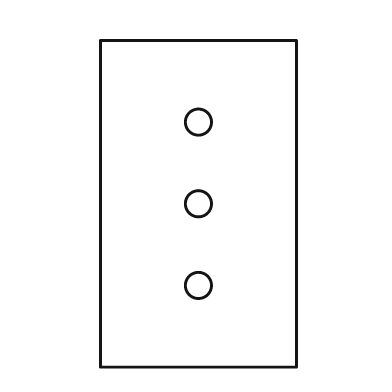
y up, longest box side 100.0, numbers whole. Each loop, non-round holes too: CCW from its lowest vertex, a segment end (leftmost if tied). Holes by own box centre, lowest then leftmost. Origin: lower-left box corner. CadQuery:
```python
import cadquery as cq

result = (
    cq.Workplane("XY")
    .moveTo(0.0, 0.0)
    .lineTo(60.0, 0.0)
    .lineTo(60.0, 100.0)
    .lineTo(0.0, 100.0)
    .close()
    .moveTo(30.0, 25.0)
    .circle(4.0)
    .moveTo(30.0, 50.0)
    .circle(4.0)
    .moveTo(30.0, 75.0)
    .circle(4.0)
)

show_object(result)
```